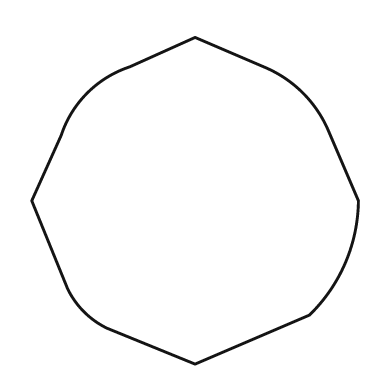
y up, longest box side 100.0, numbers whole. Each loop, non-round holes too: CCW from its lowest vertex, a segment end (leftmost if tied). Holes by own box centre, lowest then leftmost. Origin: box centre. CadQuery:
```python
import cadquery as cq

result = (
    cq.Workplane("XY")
    .moveTo(0.0, -50.0)
    .lineTo(35.0, -35.0)
    .threePointArc((46.0, -19.0), (50.0, 0.0))
    .lineTo(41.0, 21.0)
    .threePointArc((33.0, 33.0), (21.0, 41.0))
    .lineTo(0.0, 50.0)
    .lineTo(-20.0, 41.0)
    .threePointArc((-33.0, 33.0), (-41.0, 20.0))
    .lineTo(-50.0, 0.0)
    .lineTo(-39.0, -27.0)
    .threePointArc((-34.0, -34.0), (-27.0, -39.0))
    .close()
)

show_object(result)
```